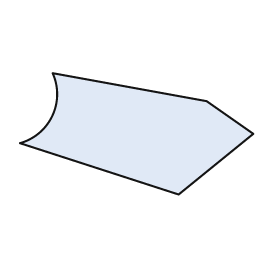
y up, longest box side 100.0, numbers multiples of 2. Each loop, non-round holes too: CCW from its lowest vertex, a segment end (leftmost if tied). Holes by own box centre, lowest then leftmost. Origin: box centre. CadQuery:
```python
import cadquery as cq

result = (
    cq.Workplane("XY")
    .moveTo(18.0, -26.0)
    .lineTo(50.0, 0.0)
    .lineTo(30.0, 14.0)
    .lineTo(-36.0, 26.0)
    .threePointArc((-36.0, 8.0), (-50.0, -4.0))
    .close()
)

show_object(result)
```